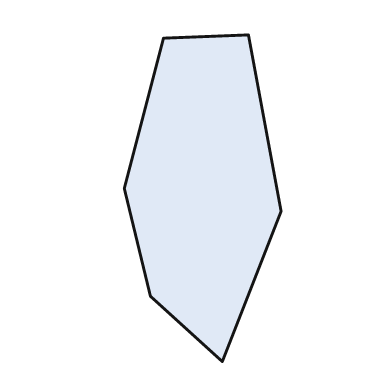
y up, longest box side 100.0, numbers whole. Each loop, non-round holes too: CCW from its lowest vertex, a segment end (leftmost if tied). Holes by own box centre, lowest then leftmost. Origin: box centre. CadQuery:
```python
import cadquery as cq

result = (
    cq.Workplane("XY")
    .moveTo(6.0, -50.0)
    .lineTo(24.0, -4.0)
    .lineTo(14.0, 50.0)
    .lineTo(-12.0, 49.0)
    .lineTo(-24.0, 3.0)
    .lineTo(-16.0, -30.0)
    .close()
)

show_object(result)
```